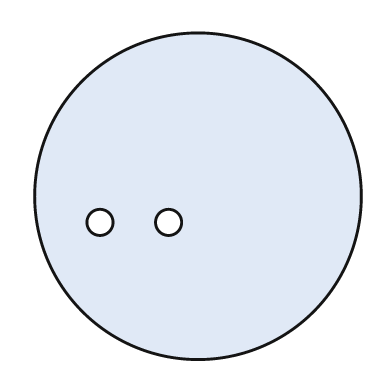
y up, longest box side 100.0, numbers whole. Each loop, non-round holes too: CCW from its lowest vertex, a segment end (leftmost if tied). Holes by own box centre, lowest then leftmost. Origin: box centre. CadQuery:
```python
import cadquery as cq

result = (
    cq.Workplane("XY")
    .moveTo(0.0, 0.0)
    .circle(50.0)
    .moveTo(-30.0, -8.0)
    .circle(4.0)
    .moveTo(-9.0, -8.0)
    .circle(4.0)
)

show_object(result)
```